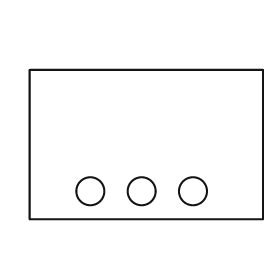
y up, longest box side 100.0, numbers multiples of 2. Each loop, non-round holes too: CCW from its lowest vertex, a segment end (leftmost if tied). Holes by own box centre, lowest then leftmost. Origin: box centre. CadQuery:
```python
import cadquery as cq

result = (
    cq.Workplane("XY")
    .moveTo(-50.0, -32.0)
    .lineTo(50.0, -32.0)
    .lineTo(50.0, 32.0)
    .lineTo(-50.0, 32.0)
    .close()
    .moveTo(-24.0, -20.0)
    .circle(6.0)
    .moveTo(-2.0, -20.0)
    .circle(6.0)
    .moveTo(20.0, -20.0)
    .circle(6.0)
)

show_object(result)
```